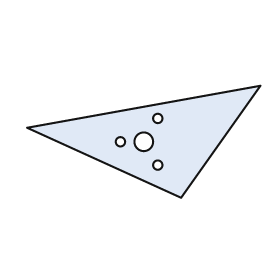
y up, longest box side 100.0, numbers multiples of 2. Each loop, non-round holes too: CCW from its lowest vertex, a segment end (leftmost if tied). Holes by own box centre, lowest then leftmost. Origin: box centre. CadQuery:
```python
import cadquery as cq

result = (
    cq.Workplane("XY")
    .moveTo(16.0, -24.0)
    .lineTo(50.0, 24.0)
    .lineTo(-50.0, 6.0)
    .close()
    .moveTo(6.0, -10.0)
    .circle(2.0)
    .moveTo(-10.0, 0.0)
    .circle(2.0)
    .moveTo(0.0, 0.0)
    .circle(4.0)
    .moveTo(6.0, 10.0)
    .circle(2.0)
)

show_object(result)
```